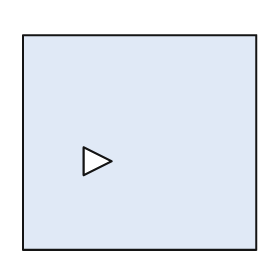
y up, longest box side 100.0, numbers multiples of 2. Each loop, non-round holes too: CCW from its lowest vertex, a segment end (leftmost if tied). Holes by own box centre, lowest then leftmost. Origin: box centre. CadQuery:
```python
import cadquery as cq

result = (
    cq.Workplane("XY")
    .moveTo(-50.0, -46.0)
    .lineTo(50.0, -46.0)
    .lineTo(50.0, 46.0)
    .lineTo(-50.0, 46.0)
    .close()
    .moveTo(-24.0, -14.0)
    .lineTo(-12.0, -8.0)
    .lineTo(-24.0, -2.0)
    .close()
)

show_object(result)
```